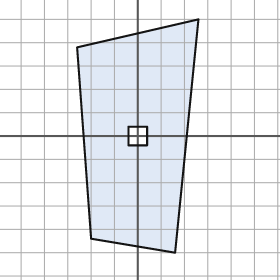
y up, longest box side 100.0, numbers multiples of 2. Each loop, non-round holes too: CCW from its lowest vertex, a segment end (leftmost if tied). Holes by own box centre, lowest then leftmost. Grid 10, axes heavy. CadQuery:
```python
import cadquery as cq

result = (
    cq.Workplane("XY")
    .moveTo(16.0, -50.0)
    .lineTo(26.0, 50.0)
    .lineTo(-26.0, 38.0)
    .lineTo(-20.0, -44.0)
    .close()
    .moveTo(-4.0, -4.0)
    .lineTo(4.0, -4.0)
    .lineTo(4.0, 4.0)
    .lineTo(-4.0, 4.0)
    .close()
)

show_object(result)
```